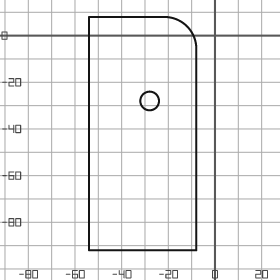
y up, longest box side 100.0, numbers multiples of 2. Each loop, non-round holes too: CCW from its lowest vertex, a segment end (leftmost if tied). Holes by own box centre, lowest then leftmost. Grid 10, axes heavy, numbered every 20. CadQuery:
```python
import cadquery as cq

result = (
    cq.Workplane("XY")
    .moveTo(-54.0, -92.0)
    .lineTo(-8.0, -92.0)
    .lineTo(-8.0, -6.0)
    .threePointArc((-12.0, 4.0), (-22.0, 8.0))
    .lineTo(-54.0, 8.0)
    .close()
    .moveTo(-28.0, -28.0)
    .circle(4.0)
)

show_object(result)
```